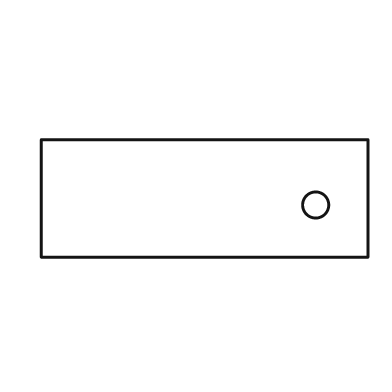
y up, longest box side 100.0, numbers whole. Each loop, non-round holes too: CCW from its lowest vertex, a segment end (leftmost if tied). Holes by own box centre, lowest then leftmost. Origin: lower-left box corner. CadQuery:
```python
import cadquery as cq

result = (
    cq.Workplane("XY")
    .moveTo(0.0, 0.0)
    .lineTo(100.0, 0.0)
    .lineTo(100.0, 36.0)
    .lineTo(0.0, 36.0)
    .close()
    .moveTo(84.0, 16.0)
    .circle(4.0)
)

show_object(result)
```